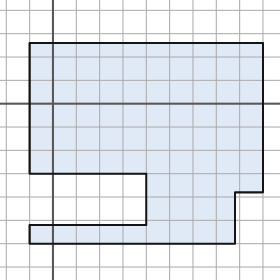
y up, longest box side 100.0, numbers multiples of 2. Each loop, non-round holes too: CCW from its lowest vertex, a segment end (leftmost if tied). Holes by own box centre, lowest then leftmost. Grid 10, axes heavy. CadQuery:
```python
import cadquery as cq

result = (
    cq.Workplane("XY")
    .moveTo(-10.0, -60.0)
    .lineTo(78.0, -60.0)
    .lineTo(78.0, -38.0)
    .lineTo(90.0, -38.0)
    .lineTo(90.0, 26.0)
    .lineTo(-10.0, 26.0)
    .lineTo(-10.0, -30.0)
    .lineTo(40.0, -30.0)
    .lineTo(40.0, -52.0)
    .lineTo(-10.0, -52.0)
    .close()
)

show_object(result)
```